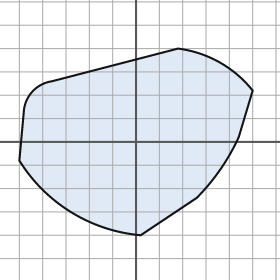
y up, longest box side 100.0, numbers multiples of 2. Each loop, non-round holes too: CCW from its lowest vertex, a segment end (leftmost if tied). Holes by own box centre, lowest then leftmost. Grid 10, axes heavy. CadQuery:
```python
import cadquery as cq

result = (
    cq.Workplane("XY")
    .moveTo(2.0, -40.0)
    .lineTo(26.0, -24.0)
    .threePointArc((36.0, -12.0), (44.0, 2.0))
    .lineTo(50.0, 22.0)
    .threePointArc((36.0, 34.0), (18.0, 40.0))
    .lineTo(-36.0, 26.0)
    .threePointArc((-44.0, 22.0), (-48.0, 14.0))
    .lineTo(-50.0, -8.0)
    .threePointArc((-28.0, -30.0), (2.0, -40.0))
    .close()
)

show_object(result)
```